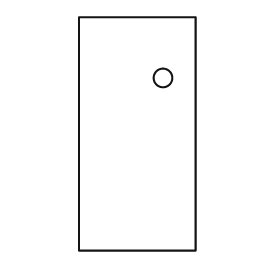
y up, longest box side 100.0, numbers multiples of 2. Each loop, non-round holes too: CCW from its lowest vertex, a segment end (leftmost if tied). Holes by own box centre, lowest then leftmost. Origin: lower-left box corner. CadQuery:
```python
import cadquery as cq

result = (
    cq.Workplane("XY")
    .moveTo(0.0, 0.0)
    .lineTo(50.0, 0.0)
    .lineTo(50.0, 100.0)
    .lineTo(0.0, 100.0)
    .close()
    .moveTo(36.0, 74.0)
    .circle(4.0)
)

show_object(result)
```